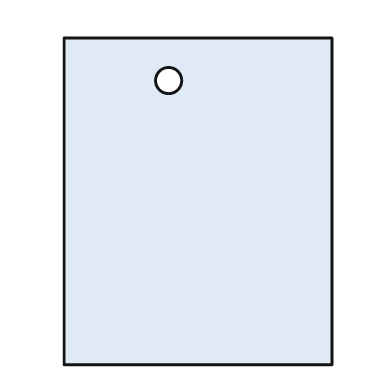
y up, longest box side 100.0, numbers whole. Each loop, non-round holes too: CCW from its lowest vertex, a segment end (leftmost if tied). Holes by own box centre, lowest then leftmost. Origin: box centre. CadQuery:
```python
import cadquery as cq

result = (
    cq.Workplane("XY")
    .moveTo(-41.0, -50.0)
    .lineTo(41.0, -50.0)
    .lineTo(41.0, 50.0)
    .lineTo(-41.0, 50.0)
    .close()
    .moveTo(-9.0, 37.0)
    .circle(4.0)
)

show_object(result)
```